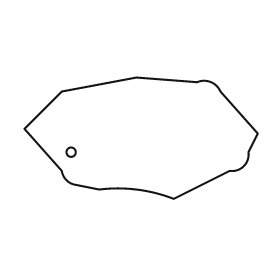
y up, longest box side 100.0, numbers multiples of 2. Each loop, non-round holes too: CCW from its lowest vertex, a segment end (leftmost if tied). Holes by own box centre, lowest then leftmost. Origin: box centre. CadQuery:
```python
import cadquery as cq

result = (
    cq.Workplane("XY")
    .moveTo(14.0, -26.0)
    .lineTo(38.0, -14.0)
    .threePointArc((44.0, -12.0), (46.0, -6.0))
    .lineTo(50.0, 2.0)
    .lineTo(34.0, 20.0)
    .threePointArc((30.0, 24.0), (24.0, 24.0))
    .lineTo(-2.0, 26.0)
    .lineTo(-34.0, 20.0)
    .lineTo(-50.0, 4.0)
    .lineTo(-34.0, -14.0)
    .threePointArc((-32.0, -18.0), (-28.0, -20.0))
    .lineTo(-18.0, -22.0)
    .threePointArc((-2.0, -22.0), (14.0, -26.0))
    .close()
    .moveTo(-30.0, -6.0)
    .circle(2.0)
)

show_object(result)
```